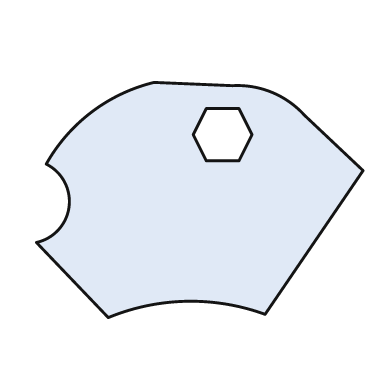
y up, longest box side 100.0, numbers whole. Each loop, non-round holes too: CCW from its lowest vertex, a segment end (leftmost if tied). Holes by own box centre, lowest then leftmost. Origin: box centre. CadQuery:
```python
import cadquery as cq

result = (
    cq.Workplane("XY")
    .moveTo(-28.0, -36.0)
    .threePointArc((-4.0, -31.0), (20.0, -35.0))
    .lineTo(50.0, 9.0)
    .lineTo(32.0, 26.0)
    .threePointArc((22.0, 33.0), (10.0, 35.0))
    .lineTo(-14.0, 36.0)
    .threePointArc((-33.0, 27.0), (-47.0, 11.0))
    .threePointArc((-40.0, -2.0), (-50.0, -13.0))
    .close()
    .moveTo(2.0, 12.0)
    .lineTo(12.0, 12.0)
    .lineTo(16.0, 20.0)
    .lineTo(12.0, 28.0)
    .lineTo(2.0, 28.0)
    .lineTo(-2.0, 20.0)
    .close()
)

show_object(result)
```